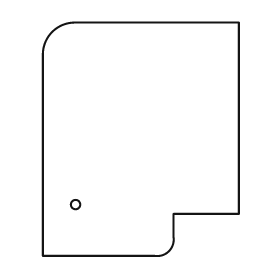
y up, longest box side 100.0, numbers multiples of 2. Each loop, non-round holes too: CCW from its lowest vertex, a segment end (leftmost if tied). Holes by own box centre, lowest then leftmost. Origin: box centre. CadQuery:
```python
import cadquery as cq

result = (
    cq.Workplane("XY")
    .moveTo(-42.0, -50.0)
    .lineTo(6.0, -50.0)
    .threePointArc((12.0, -48.0), (14.0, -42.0))
    .lineTo(14.0, -32.0)
    .lineTo(42.0, -32.0)
    .lineTo(42.0, 50.0)
    .lineTo(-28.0, 50.0)
    .threePointArc((-38.0, 46.0), (-42.0, 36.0))
    .close()
    .moveTo(-28.0, -28.0)
    .circle(2.0)
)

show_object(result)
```